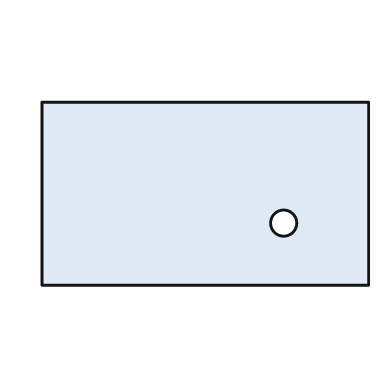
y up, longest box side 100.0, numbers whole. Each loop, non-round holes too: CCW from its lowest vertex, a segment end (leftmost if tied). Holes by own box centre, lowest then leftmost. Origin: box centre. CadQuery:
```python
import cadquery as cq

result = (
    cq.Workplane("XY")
    .moveTo(-50.0, -28.0)
    .lineTo(50.0, -28.0)
    .lineTo(50.0, 28.0)
    .lineTo(-50.0, 28.0)
    .close()
    .moveTo(24.0, -9.0)
    .circle(4.0)
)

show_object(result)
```